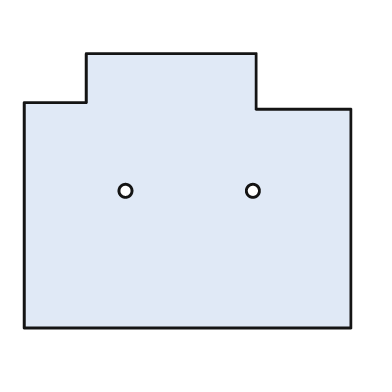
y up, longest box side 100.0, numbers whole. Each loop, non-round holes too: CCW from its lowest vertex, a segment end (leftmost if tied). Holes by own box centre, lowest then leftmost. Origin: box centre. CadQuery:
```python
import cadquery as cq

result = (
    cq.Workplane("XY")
    .moveTo(-50.0, -42.0)
    .lineTo(50.0, -42.0)
    .lineTo(50.0, 25.0)
    .lineTo(21.0, 25.0)
    .lineTo(21.0, 42.0)
    .lineTo(-31.0, 42.0)
    .lineTo(-31.0, 27.0)
    .lineTo(-50.0, 27.0)
    .close()
    .moveTo(-19.0, 0.0)
    .circle(2.0)
    .moveTo(20.0, 0.0)
    .circle(2.0)
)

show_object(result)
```